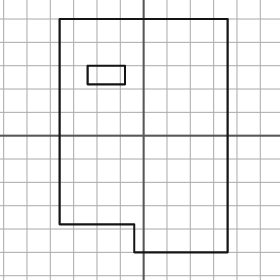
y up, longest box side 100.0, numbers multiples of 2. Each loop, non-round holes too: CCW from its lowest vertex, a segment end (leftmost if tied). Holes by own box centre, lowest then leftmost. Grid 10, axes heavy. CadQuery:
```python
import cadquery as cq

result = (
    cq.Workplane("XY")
    .moveTo(-4.0, -50.0)
    .lineTo(36.0, -50.0)
    .lineTo(36.0, 50.0)
    .lineTo(-36.0, 50.0)
    .lineTo(-36.0, -38.0)
    .lineTo(-4.0, -38.0)
    .close()
    .moveTo(-24.0, 22.0)
    .lineTo(-8.0, 22.0)
    .lineTo(-8.0, 30.0)
    .lineTo(-24.0, 30.0)
    .close()
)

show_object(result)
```